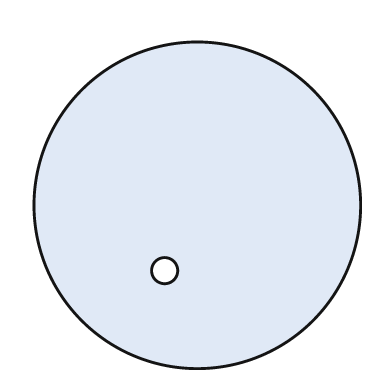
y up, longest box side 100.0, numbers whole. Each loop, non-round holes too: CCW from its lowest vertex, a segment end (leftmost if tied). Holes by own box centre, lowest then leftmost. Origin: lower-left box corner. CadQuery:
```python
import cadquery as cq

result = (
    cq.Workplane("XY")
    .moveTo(50.0, 50.0)
    .circle(50.0)
    .moveTo(40.0, 30.0)
    .circle(4.0)
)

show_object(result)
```